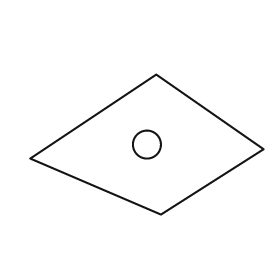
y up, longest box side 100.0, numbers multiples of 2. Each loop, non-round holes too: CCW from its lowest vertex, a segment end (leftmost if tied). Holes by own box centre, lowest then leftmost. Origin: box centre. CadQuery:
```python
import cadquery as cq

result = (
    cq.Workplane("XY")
    .moveTo(6.0, -30.0)
    .lineTo(50.0, -2.0)
    .lineTo(4.0, 30.0)
    .lineTo(-50.0, -6.0)
    .close()
    .moveTo(0.0, 0.0)
    .circle(6.0)
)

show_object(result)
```